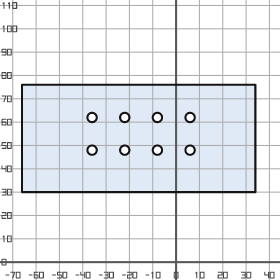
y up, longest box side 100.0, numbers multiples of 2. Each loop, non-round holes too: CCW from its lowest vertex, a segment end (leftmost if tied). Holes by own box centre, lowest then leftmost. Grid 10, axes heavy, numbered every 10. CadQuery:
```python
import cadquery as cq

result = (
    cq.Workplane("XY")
    .moveTo(-66.0, 30.0)
    .lineTo(34.0, 30.0)
    .lineTo(34.0, 76.0)
    .lineTo(-66.0, 76.0)
    .close()
    .moveTo(-36.0, 48.0)
    .circle(2.0)
    .moveTo(-22.0, 48.0)
    .circle(2.0)
    .moveTo(-8.0, 48.0)
    .circle(2.0)
    .moveTo(6.0, 48.0)
    .circle(2.0)
    .moveTo(-36.0, 62.0)
    .circle(2.0)
    .moveTo(-22.0, 62.0)
    .circle(2.0)
    .moveTo(-8.0, 62.0)
    .circle(2.0)
    .moveTo(6.0, 62.0)
    .circle(2.0)
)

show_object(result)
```